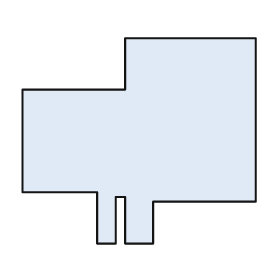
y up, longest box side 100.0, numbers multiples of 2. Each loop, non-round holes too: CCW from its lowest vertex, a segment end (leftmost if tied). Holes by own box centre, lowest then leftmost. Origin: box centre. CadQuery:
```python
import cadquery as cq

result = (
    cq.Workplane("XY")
    .moveTo(-18.0, -44.0)
    .lineTo(-10.0, -44.0)
    .lineTo(-10.0, -24.0)
    .lineTo(-6.0, -24.0)
    .lineTo(-6.0, -44.0)
    .lineTo(6.0, -44.0)
    .lineTo(6.0, -26.0)
    .lineTo(50.0, -26.0)
    .lineTo(50.0, 44.0)
    .lineTo(-6.0, 44.0)
    .lineTo(-6.0, 22.0)
    .lineTo(-50.0, 22.0)
    .lineTo(-50.0, -22.0)
    .lineTo(-18.0, -22.0)
    .close()
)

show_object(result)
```